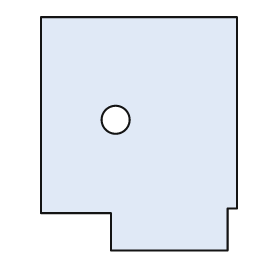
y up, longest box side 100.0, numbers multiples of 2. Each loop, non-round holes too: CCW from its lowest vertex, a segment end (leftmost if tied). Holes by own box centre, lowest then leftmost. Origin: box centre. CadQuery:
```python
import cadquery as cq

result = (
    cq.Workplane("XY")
    .moveTo(-12.0, -50.0)
    .lineTo(38.0, -50.0)
    .lineTo(38.0, -32.0)
    .lineTo(42.0, -32.0)
    .lineTo(42.0, 50.0)
    .lineTo(-42.0, 50.0)
    .lineTo(-42.0, -34.0)
    .lineTo(-12.0, -34.0)
    .close()
    .moveTo(-10.0, 6.0)
    .circle(6.0)
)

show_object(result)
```